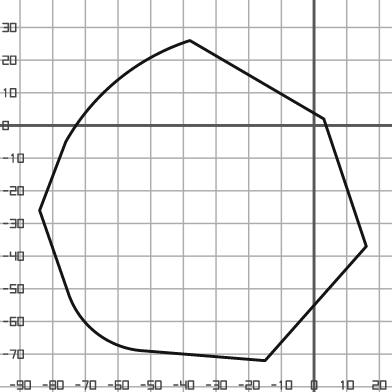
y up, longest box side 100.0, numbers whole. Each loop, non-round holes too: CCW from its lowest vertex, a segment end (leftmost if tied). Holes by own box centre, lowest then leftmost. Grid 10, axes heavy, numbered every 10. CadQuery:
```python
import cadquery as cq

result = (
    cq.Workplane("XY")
    .moveTo(-15.0, -72.0)
    .lineTo(16.0, -37.0)
    .lineTo(3.0, 2.0)
    .lineTo(-38.0, 26.0)
    .threePointArc((-60.0, 14.0), (-76.0, -5.0))
    .lineTo(-84.0, -26.0)
    .lineTo(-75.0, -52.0)
    .threePointArc((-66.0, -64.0), (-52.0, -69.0))
    .close()
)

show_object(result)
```